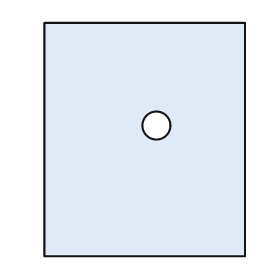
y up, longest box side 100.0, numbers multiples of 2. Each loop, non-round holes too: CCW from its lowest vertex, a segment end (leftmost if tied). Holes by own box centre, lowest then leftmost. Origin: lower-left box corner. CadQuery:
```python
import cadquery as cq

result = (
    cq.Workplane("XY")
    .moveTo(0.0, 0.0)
    .lineTo(86.0, 0.0)
    .lineTo(86.0, 100.0)
    .lineTo(0.0, 100.0)
    .close()
    .moveTo(48.0, 56.0)
    .circle(6.0)
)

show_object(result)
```